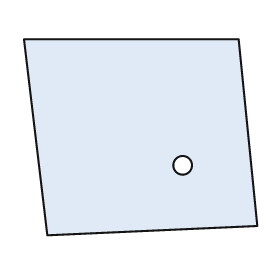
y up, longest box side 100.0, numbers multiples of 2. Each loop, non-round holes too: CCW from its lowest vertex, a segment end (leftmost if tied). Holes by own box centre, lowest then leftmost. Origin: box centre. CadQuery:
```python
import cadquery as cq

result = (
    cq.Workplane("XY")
    .moveTo(-40.0, -42.0)
    .lineTo(50.0, -38.0)
    .lineTo(42.0, 42.0)
    .lineTo(-50.0, 42.0)
    .close()
    .moveTo(18.0, -12.0)
    .circle(4.0)
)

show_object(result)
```